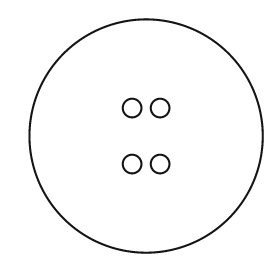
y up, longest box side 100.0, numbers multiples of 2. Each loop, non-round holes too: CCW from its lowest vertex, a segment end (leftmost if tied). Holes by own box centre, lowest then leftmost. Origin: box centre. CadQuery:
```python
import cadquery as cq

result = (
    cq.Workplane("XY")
    .moveTo(0.0, 0.0)
    .circle(50.0)
    .moveTo(-6.0, -12.0)
    .circle(4.0)
    .moveTo(6.0, -12.0)
    .circle(4.0)
    .moveTo(-6.0, 12.0)
    .circle(4.0)
    .moveTo(6.0, 12.0)
    .circle(4.0)
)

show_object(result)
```